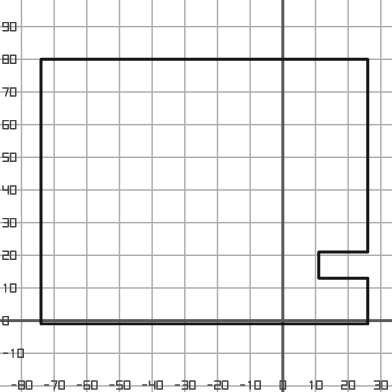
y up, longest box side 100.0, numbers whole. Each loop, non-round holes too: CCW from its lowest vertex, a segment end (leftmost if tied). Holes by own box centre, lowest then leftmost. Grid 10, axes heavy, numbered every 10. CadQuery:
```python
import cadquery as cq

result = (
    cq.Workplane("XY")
    .moveTo(-74.0, -1.0)
    .lineTo(26.0, -1.0)
    .lineTo(26.0, 13.0)
    .lineTo(11.0, 13.0)
    .lineTo(11.0, 21.0)
    .lineTo(26.0, 21.0)
    .lineTo(26.0, 80.0)
    .lineTo(-74.0, 80.0)
    .close()
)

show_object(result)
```